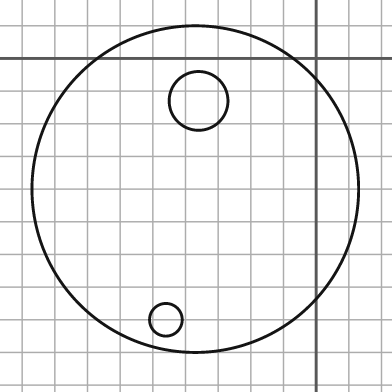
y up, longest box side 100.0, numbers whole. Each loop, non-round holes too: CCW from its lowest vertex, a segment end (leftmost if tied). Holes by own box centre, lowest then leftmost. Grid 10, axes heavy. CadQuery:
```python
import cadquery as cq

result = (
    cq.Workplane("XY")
    .moveTo(-37.0, -40.0)
    .circle(50.0)
    .moveTo(-46.0, -80.0)
    .circle(5.0)
    .moveTo(-36.0, -13.0)
    .circle(9.0)
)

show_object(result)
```